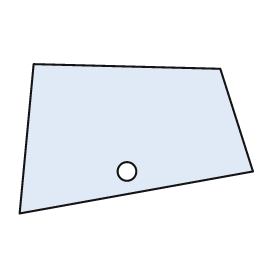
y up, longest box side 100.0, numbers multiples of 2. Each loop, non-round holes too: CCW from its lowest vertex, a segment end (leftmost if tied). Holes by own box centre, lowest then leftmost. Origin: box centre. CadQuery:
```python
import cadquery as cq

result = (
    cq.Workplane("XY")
    .moveTo(-50.0, -32.0)
    .lineTo(50.0, -14.0)
    .lineTo(36.0, 30.0)
    .lineTo(-44.0, 32.0)
    .close()
    .moveTo(-4.0, -14.0)
    .circle(4.0)
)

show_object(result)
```